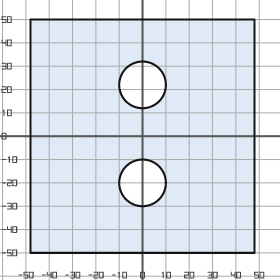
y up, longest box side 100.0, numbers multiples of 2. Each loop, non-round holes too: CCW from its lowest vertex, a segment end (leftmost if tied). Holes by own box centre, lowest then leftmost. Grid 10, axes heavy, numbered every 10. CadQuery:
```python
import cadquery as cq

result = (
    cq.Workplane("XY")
    .moveTo(-48.0, -50.0)
    .lineTo(48.0, -50.0)
    .lineTo(48.0, 50.0)
    .lineTo(-48.0, 50.0)
    .close()
    .moveTo(0.0, -20.0)
    .circle(10.0)
    .moveTo(0.0, 22.0)
    .circle(10.0)
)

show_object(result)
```